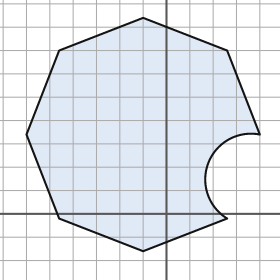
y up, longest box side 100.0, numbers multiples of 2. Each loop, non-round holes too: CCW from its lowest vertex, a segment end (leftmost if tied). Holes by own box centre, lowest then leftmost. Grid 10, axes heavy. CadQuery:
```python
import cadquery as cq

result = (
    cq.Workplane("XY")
    .moveTo(-10.0, -16.0)
    .lineTo(26.0, -2.0)
    .threePointArc((18.0, 22.0), (40.0, 34.0))
    .lineTo(26.0, 70.0)
    .lineTo(-10.0, 84.0)
    .lineTo(-46.0, 70.0)
    .lineTo(-60.0, 34.0)
    .lineTo(-46.0, -2.0)
    .close()
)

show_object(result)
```